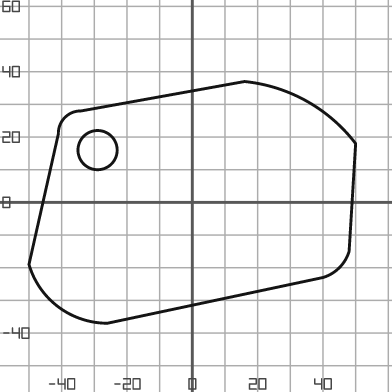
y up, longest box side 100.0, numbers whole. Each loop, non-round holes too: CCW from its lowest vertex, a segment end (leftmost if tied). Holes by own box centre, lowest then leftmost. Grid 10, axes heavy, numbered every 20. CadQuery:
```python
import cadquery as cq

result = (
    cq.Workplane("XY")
    .moveTo(-26.0, -37.0)
    .lineTo(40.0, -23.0)
    .threePointArc((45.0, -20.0), (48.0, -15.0))
    .lineTo(50.0, 18.0)
    .threePointArc((35.0, 31.0), (16.0, 37.0))
    .lineTo(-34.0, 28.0)
    .threePointArc((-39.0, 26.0), (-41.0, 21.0))
    .lineTo(-50.0, -19.0)
    .threePointArc((-41.0, -32.0), (-26.0, -37.0))
    .close()
    .moveTo(-29.0, 16.0)
    .circle(6.0)
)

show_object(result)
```